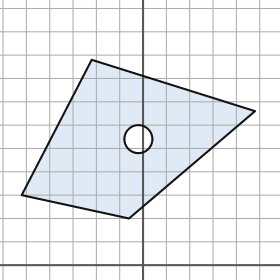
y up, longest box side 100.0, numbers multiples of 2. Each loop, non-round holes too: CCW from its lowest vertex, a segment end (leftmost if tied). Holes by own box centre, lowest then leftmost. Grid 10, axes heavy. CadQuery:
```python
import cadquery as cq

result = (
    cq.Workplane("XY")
    .moveTo(-6.0, 20.0)
    .lineTo(48.0, 66.0)
    .lineTo(-22.0, 88.0)
    .lineTo(-52.0, 30.0)
    .close()
    .moveTo(-2.0, 54.0)
    .circle(6.0)
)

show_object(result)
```